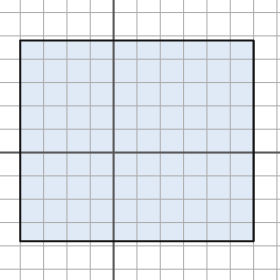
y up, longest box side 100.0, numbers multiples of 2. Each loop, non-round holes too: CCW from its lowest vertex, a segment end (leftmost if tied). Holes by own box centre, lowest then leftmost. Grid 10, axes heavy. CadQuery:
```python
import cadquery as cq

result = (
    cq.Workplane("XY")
    .moveTo(-40.0, -38.0)
    .lineTo(60.0, -38.0)
    .lineTo(60.0, 48.0)
    .lineTo(-40.0, 48.0)
    .close()
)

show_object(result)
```